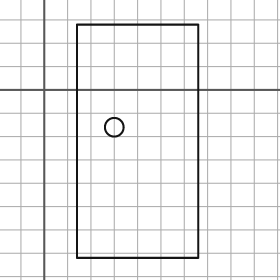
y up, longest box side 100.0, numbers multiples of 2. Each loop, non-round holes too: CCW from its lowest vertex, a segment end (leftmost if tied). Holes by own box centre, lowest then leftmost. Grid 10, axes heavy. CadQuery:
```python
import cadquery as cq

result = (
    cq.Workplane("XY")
    .moveTo(14.0, -72.0)
    .lineTo(66.0, -72.0)
    .lineTo(66.0, 28.0)
    .lineTo(14.0, 28.0)
    .close()
    .moveTo(30.0, -16.0)
    .circle(4.0)
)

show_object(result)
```